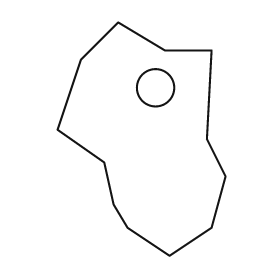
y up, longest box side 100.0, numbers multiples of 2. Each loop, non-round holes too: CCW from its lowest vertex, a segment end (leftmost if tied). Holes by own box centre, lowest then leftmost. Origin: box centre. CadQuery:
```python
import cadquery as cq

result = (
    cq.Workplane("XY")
    .moveTo(12.0, -50.0)
    .lineTo(30.0, -38.0)
    .lineTo(36.0, -16.0)
    .lineTo(28.0, 0.0)
    .lineTo(30.0, 38.0)
    .lineTo(10.0, 38.0)
    .lineTo(-10.0, 50.0)
    .lineTo(-26.0, 34.0)
    .lineTo(-36.0, 4.0)
    .lineTo(-16.0, -10.0)
    .lineTo(-12.0, -28.0)
    .lineTo(-6.0, -38.0)
    .close()
    .moveTo(6.0, 22.0)
    .circle(8.0)
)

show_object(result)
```